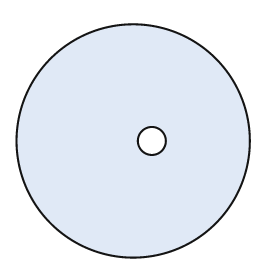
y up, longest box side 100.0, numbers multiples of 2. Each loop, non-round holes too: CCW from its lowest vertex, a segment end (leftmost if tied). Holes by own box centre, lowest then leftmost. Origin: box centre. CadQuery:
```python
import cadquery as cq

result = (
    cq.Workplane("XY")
    .moveTo(0.0, 0.0)
    .circle(50.0)
    .moveTo(8.0, 0.0)
    .circle(6.0)
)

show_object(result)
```